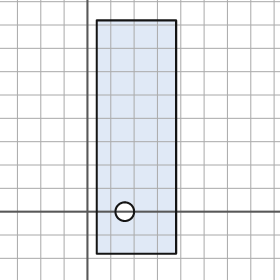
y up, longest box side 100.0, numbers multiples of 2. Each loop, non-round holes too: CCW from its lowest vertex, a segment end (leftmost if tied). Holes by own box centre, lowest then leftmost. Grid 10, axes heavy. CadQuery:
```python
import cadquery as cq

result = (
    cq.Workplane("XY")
    .moveTo(4.0, -18.0)
    .lineTo(38.0, -18.0)
    .lineTo(38.0, 82.0)
    .lineTo(4.0, 82.0)
    .close()
    .moveTo(16.0, 0.0)
    .circle(4.0)
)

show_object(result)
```